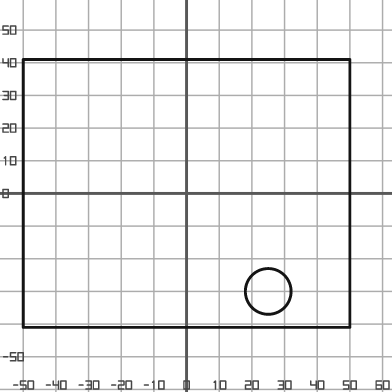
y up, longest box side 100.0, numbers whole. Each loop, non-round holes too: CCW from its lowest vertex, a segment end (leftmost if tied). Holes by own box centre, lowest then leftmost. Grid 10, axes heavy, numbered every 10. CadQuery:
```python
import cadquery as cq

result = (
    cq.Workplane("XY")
    .moveTo(-50.0, -41.0)
    .lineTo(50.0, -41.0)
    .lineTo(50.0, 41.0)
    .lineTo(-50.0, 41.0)
    .close()
    .moveTo(25.0, -30.0)
    .circle(7.0)
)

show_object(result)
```